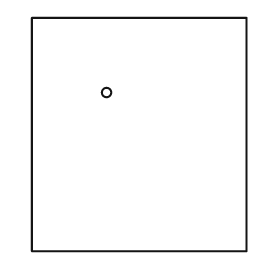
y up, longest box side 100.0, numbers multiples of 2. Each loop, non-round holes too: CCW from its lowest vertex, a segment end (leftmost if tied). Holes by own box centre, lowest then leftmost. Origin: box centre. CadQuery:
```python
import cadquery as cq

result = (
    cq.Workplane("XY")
    .moveTo(-46.0, -50.0)
    .lineTo(46.0, -50.0)
    .lineTo(46.0, 50.0)
    .lineTo(-46.0, 50.0)
    .close()
    .moveTo(-14.0, 18.0)
    .circle(2.0)
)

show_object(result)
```